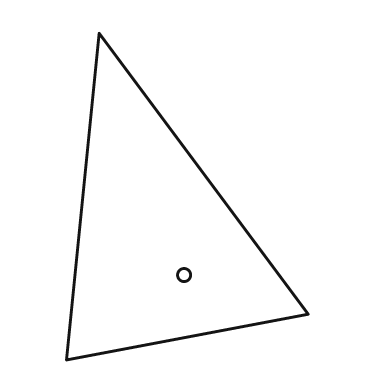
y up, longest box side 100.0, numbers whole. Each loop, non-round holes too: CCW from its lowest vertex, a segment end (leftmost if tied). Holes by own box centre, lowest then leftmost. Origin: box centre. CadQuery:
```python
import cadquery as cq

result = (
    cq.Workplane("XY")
    .moveTo(-37.0, -50.0)
    .lineTo(37.0, -36.0)
    .lineTo(-27.0, 50.0)
    .close()
    .moveTo(-1.0, -24.0)
    .circle(2.0)
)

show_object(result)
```